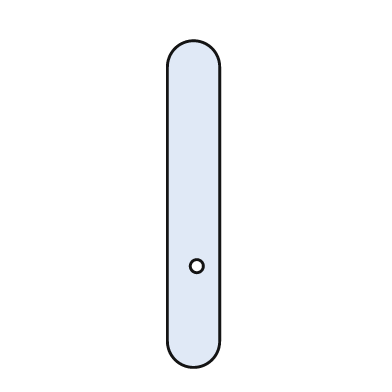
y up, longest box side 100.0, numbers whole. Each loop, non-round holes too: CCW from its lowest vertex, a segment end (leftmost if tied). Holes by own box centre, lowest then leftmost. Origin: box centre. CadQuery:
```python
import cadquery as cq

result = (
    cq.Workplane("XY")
    .moveTo(-8.0, -42.0)
    .threePointArc((0.0, -50.0), (8.0, -42.0))
    .lineTo(8.0, 42.0)
    .threePointArc((0.0, 50.0), (-8.0, 42.0))
    .close()
    .moveTo(1.0, -19.0)
    .circle(2.0)
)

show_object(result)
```